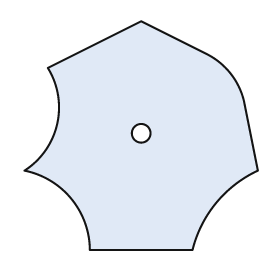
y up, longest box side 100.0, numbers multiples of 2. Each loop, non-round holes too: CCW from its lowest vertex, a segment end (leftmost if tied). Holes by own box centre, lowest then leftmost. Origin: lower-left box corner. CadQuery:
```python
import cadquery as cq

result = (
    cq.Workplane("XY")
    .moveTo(28.0, 0.0)
    .lineTo(72.0, 0.0)
    .threePointArc((82.0, 20.0), (100.0, 34.0))
    .lineTo(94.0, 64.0)
    .threePointArc((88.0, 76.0), (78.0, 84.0))
    .lineTo(50.0, 98.0)
    .lineTo(10.0, 78.0)
    .threePointArc((14.0, 54.0), (0.0, 34.0))
    .threePointArc((20.0, 22.0), (28.0, 0.0))
    .close()
    .moveTo(50.0, 50.0)
    .circle(4.0)
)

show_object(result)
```